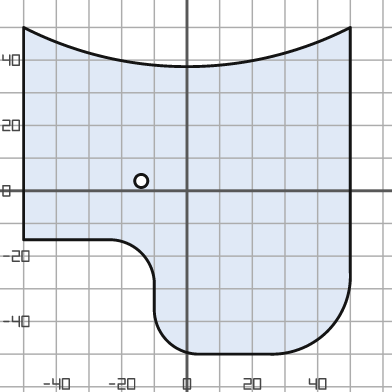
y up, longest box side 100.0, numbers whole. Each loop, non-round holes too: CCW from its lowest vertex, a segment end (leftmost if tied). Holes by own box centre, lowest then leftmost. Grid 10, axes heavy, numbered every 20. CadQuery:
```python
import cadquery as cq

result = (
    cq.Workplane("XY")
    .moveTo(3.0, -50.0)
    .lineTo(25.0, -50.0)
    .threePointArc((43.0, -43.0), (50.0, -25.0))
    .lineTo(50.0, 50.0)
    .threePointArc((0.0, 38.0), (-50.0, 50.0))
    .lineTo(-50.0, -15.0)
    .lineTo(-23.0, -15.0)
    .threePointArc((-14.0, -19.0), (-10.0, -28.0))
    .lineTo(-10.0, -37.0)
    .threePointArc((-6.0, -46.0), (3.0, -50.0))
    .close()
    .moveTo(-14.0, 3.0)
    .circle(2.0)
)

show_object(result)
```